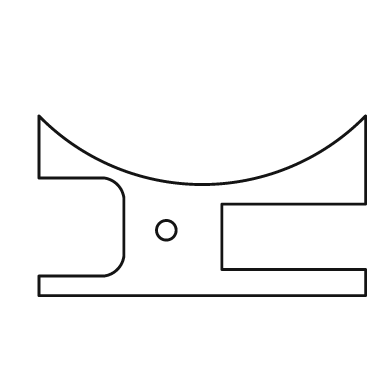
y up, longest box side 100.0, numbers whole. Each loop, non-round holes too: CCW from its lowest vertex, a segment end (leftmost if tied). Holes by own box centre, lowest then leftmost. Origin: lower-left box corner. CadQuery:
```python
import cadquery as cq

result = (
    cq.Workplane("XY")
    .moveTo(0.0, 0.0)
    .lineTo(100.0, 0.0)
    .lineTo(100.0, 8.0)
    .lineTo(56.0, 8.0)
    .lineTo(56.0, 28.0)
    .lineTo(100.0, 28.0)
    .lineTo(100.0, 55.0)
    .threePointArc((50.0, 34.0), (0.0, 55.0))
    .lineTo(0.0, 36.0)
    .lineTo(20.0, 36.0)
    .threePointArc((24.0, 34.0), (26.0, 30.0))
    .lineTo(26.0, 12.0)
    .threePointArc((24.0, 8.0), (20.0, 6.0))
    .lineTo(0.0, 6.0)
    .close()
    .moveTo(39.0, 20.0)
    .circle(3.0)
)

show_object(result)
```